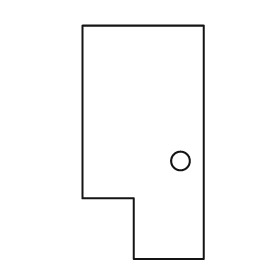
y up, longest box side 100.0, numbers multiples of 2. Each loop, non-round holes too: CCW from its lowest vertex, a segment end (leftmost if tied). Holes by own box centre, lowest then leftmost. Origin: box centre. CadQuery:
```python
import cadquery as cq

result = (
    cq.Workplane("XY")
    .moveTo(-4.0, -50.0)
    .lineTo(26.0, -50.0)
    .lineTo(26.0, 50.0)
    .lineTo(-26.0, 50.0)
    .lineTo(-26.0, -24.0)
    .lineTo(-4.0, -24.0)
    .close()
    .moveTo(16.0, -8.0)
    .circle(4.0)
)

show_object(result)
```